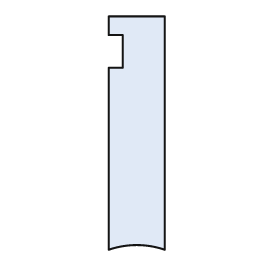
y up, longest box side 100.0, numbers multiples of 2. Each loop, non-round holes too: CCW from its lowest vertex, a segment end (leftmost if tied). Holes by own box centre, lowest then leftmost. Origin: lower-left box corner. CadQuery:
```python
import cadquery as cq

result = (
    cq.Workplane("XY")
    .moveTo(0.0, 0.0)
    .threePointArc((12.0, 2.0), (24.0, 0.0))
    .lineTo(24.0, 100.0)
    .lineTo(0.0, 100.0)
    .lineTo(0.0, 92.0)
    .lineTo(6.0, 92.0)
    .lineTo(6.0, 78.0)
    .lineTo(0.0, 78.0)
    .close()
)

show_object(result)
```